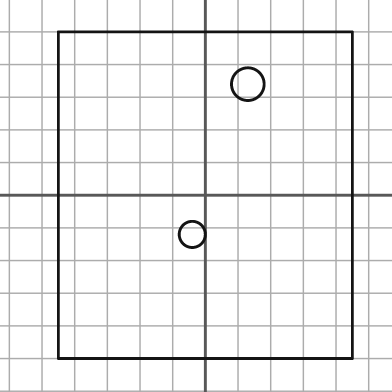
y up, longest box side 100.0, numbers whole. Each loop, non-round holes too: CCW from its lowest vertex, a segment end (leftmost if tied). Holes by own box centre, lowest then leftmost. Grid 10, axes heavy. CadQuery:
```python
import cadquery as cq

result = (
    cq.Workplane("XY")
    .moveTo(-45.0, -50.0)
    .lineTo(45.0, -50.0)
    .lineTo(45.0, 50.0)
    .lineTo(-45.0, 50.0)
    .close()
    .moveTo(-4.0, -12.0)
    .circle(4.0)
    .moveTo(13.0, 34.0)
    .circle(5.0)
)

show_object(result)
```